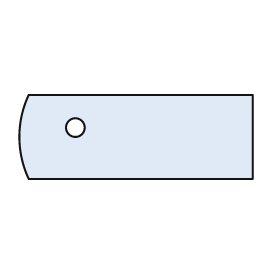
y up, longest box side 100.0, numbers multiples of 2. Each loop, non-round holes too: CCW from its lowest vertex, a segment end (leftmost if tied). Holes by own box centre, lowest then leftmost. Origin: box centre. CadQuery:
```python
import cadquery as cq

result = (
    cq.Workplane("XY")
    .moveTo(-46.0, -18.0)
    .lineTo(50.0, -18.0)
    .lineTo(50.0, 18.0)
    .lineTo(-46.0, 18.0)
    .threePointArc((-50.0, 0.0), (-46.0, -18.0))
    .close()
    .moveTo(-26.0, 4.0)
    .circle(4.0)
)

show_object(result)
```